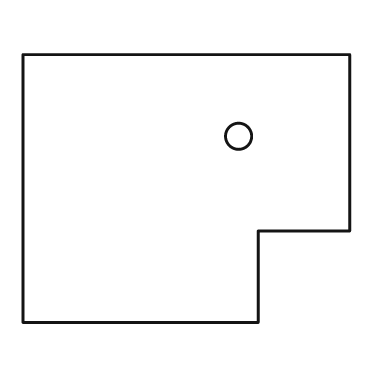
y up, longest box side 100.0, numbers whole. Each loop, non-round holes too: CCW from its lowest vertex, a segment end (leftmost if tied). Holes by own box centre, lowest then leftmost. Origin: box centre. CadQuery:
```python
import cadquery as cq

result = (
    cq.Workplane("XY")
    .moveTo(-50.0, -41.0)
    .lineTo(22.0, -41.0)
    .lineTo(22.0, -13.0)
    .lineTo(50.0, -13.0)
    .lineTo(50.0, 41.0)
    .lineTo(-50.0, 41.0)
    .close()
    .moveTo(16.0, 16.0)
    .circle(4.0)
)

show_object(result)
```